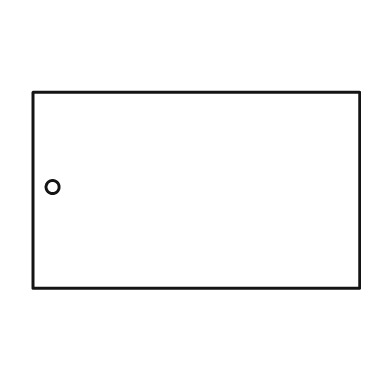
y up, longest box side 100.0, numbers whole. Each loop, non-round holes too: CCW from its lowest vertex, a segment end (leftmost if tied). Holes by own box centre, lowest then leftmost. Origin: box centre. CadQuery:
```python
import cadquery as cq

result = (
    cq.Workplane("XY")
    .moveTo(-50.0, -30.0)
    .lineTo(50.0, -30.0)
    .lineTo(50.0, 30.0)
    .lineTo(-50.0, 30.0)
    .close()
    .moveTo(-44.0, 1.0)
    .circle(2.0)
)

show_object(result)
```